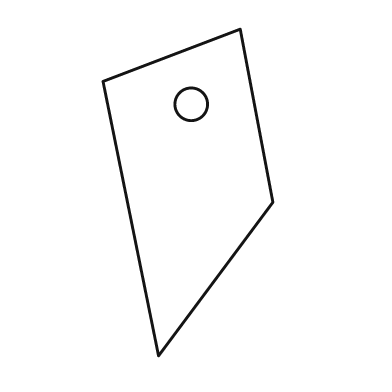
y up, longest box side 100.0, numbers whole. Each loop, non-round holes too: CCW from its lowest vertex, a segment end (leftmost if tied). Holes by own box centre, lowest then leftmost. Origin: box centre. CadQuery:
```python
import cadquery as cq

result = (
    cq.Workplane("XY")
    .moveTo(-9.0, -50.0)
    .lineTo(26.0, -3.0)
    .lineTo(16.0, 50.0)
    .lineTo(-26.0, 34.0)
    .close()
    .moveTo(1.0, 27.0)
    .circle(5.0)
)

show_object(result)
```